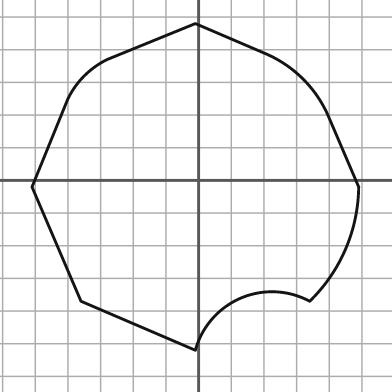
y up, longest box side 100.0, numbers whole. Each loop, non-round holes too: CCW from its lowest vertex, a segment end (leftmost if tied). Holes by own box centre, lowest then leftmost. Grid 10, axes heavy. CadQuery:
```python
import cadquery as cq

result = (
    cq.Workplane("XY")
    .moveTo(-1.0, -52.0)
    .threePointArc((13.0, -36.0), (34.0, -37.0))
    .threePointArc((45.0, -21.0), (49.0, -2.0))
    .lineTo(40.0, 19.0)
    .threePointArc((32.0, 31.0), (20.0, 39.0))
    .lineTo(-1.0, 48.0)
    .lineTo(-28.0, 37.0)
    .threePointArc((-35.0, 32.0), (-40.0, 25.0))
    .lineTo(-51.0, -2.0)
    .lineTo(-36.0, -37.0)
    .close()
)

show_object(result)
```